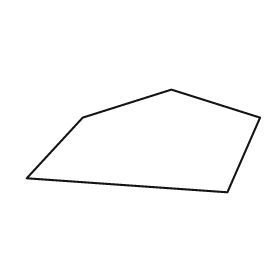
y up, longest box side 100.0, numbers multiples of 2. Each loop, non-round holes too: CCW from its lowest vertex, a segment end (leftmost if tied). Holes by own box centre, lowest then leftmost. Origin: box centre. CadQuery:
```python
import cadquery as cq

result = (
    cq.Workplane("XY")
    .moveTo(36.0, -22.0)
    .lineTo(50.0, 10.0)
    .lineTo(12.0, 22.0)
    .lineTo(-26.0, 10.0)
    .lineTo(-50.0, -16.0)
    .close()
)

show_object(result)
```